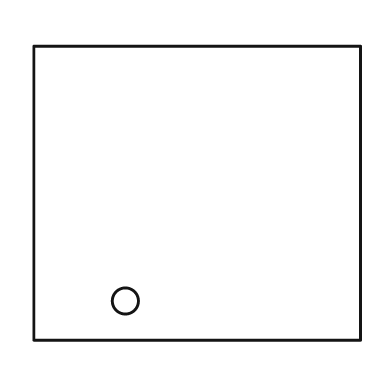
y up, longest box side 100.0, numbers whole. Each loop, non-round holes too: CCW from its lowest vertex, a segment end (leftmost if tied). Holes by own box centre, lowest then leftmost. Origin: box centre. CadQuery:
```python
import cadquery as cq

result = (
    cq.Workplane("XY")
    .moveTo(-50.0, -45.0)
    .lineTo(50.0, -45.0)
    .lineTo(50.0, 45.0)
    .lineTo(-50.0, 45.0)
    .close()
    .moveTo(-22.0, -33.0)
    .circle(4.0)
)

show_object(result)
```